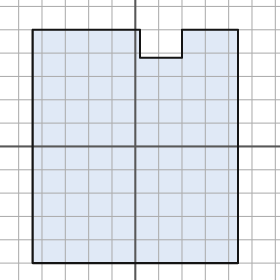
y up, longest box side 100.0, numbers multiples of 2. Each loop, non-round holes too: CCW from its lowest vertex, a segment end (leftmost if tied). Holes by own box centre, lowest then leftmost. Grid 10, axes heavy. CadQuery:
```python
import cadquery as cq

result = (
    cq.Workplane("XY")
    .moveTo(-44.0, -50.0)
    .lineTo(44.0, -50.0)
    .lineTo(44.0, 50.0)
    .lineTo(20.0, 50.0)
    .lineTo(20.0, 38.0)
    .lineTo(2.0, 38.0)
    .lineTo(2.0, 50.0)
    .lineTo(-44.0, 50.0)
    .close()
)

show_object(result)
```